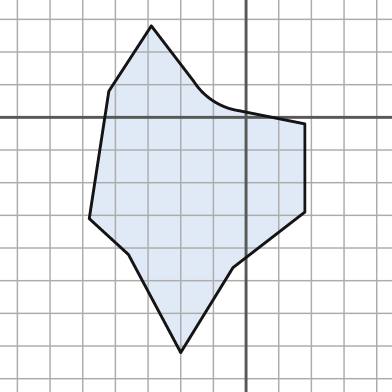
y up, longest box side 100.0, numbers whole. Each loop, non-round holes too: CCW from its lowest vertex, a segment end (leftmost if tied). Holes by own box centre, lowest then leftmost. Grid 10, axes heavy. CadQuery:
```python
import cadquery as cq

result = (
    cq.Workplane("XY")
    .moveTo(-20.0, -72.0)
    .lineTo(-4.0, -46.0)
    .lineTo(18.0, -29.0)
    .lineTo(18.0, -2.0)
    .lineTo(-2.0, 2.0)
    .threePointArc((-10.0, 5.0), (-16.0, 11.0))
    .lineTo(-29.0, 28.0)
    .lineTo(-42.0, 8.0)
    .lineTo(-48.0, -31.0)
    .lineTo(-36.0, -42.0)
    .close()
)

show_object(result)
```